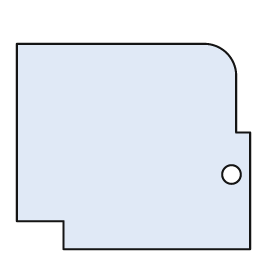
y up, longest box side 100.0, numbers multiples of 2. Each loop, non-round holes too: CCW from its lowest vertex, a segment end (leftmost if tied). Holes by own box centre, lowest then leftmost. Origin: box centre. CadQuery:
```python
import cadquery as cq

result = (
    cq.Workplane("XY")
    .moveTo(-30.0, -44.0)
    .lineTo(50.0, -44.0)
    .lineTo(50.0, 6.0)
    .lineTo(44.0, 6.0)
    .lineTo(44.0, 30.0)
    .threePointArc((40.0, 40.0), (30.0, 44.0))
    .lineTo(-50.0, 44.0)
    .lineTo(-50.0, -32.0)
    .lineTo(-30.0, -32.0)
    .close()
    .moveTo(42.0, -12.0)
    .circle(4.0)
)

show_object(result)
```